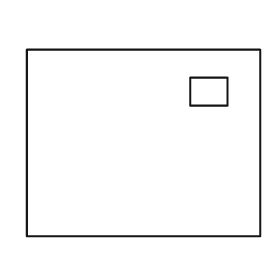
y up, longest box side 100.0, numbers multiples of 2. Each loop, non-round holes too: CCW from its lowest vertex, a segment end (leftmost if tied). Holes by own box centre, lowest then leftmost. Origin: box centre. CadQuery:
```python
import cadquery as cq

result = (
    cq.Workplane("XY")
    .moveTo(-50.0, -40.0)
    .lineTo(50.0, -40.0)
    .lineTo(50.0, 40.0)
    .lineTo(-50.0, 40.0)
    .close()
    .moveTo(20.0, 16.0)
    .lineTo(36.0, 16.0)
    .lineTo(36.0, 28.0)
    .lineTo(20.0, 28.0)
    .close()
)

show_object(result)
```